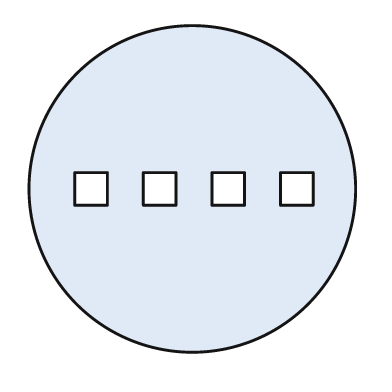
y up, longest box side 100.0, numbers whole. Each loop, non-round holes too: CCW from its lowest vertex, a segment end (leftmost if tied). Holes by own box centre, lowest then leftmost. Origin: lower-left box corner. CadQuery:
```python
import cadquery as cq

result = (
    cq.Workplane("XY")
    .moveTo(50.0, 50.0)
    .circle(50.0)
    .moveTo(14.0, 45.0)
    .lineTo(24.0, 45.0)
    .lineTo(24.0, 55.0)
    .lineTo(14.0, 55.0)
    .close()
    .moveTo(35.0, 45.0)
    .lineTo(45.0, 45.0)
    .lineTo(45.0, 55.0)
    .lineTo(35.0, 55.0)
    .close()
    .moveTo(56.0, 45.0)
    .lineTo(66.0, 45.0)
    .lineTo(66.0, 55.0)
    .lineTo(56.0, 55.0)
    .close()
    .moveTo(77.0, 45.0)
    .lineTo(87.0, 45.0)
    .lineTo(87.0, 55.0)
    .lineTo(77.0, 55.0)
    .close()
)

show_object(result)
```